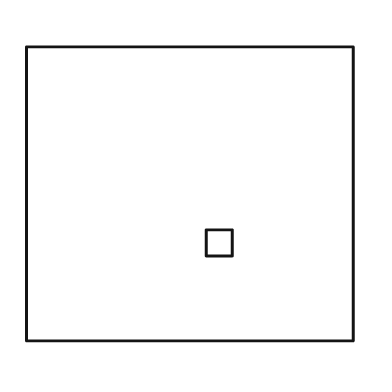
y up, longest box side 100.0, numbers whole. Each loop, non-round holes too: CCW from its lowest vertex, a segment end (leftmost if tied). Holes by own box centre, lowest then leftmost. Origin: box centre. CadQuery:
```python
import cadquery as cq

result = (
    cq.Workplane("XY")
    .moveTo(-50.0, -45.0)
    .lineTo(50.0, -45.0)
    .lineTo(50.0, 45.0)
    .lineTo(-50.0, 45.0)
    .close()
    .moveTo(5.0, -19.0)
    .lineTo(13.0, -19.0)
    .lineTo(13.0, -11.0)
    .lineTo(5.0, -11.0)
    .close()
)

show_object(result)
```